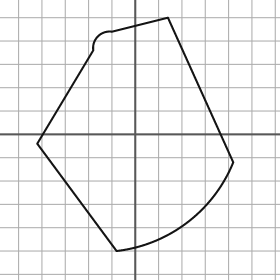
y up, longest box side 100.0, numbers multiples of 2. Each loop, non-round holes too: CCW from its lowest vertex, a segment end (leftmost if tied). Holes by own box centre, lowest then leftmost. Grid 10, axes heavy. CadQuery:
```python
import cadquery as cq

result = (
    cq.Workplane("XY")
    .moveTo(-8.0, -50.0)
    .threePointArc((22.0, -38.0), (42.0, -12.0))
    .lineTo(14.0, 50.0)
    .lineTo(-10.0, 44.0)
    .threePointArc((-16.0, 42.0), (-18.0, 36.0))
    .lineTo(-42.0, -4.0)
    .close()
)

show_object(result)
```